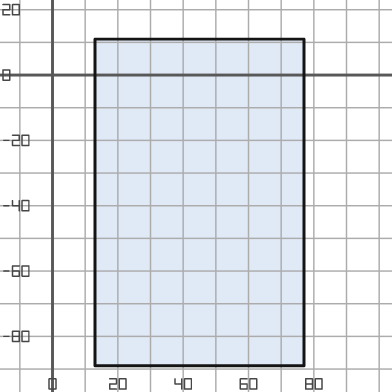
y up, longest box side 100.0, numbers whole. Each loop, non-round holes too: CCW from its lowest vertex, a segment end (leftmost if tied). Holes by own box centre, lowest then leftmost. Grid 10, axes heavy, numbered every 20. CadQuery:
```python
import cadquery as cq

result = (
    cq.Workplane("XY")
    .moveTo(13.0, -89.0)
    .lineTo(77.0, -89.0)
    .lineTo(77.0, 11.0)
    .lineTo(13.0, 11.0)
    .close()
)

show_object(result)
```